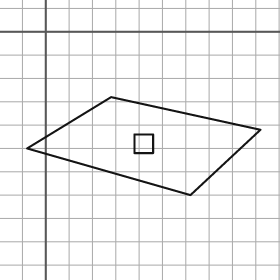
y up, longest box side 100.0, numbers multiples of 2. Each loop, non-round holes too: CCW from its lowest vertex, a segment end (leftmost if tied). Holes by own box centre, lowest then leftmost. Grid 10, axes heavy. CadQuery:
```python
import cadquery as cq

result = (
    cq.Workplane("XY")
    .moveTo(62.0, -70.0)
    .lineTo(92.0, -42.0)
    .lineTo(28.0, -28.0)
    .lineTo(-8.0, -50.0)
    .close()
    .moveTo(38.0, -52.0)
    .lineTo(46.0, -52.0)
    .lineTo(46.0, -44.0)
    .lineTo(38.0, -44.0)
    .close()
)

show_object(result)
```